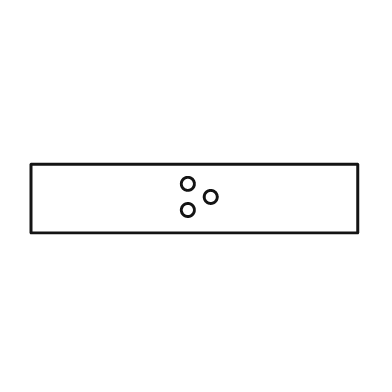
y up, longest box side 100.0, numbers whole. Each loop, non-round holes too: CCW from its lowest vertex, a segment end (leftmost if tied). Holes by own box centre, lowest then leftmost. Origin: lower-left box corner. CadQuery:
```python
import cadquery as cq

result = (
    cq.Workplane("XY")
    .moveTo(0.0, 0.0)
    .lineTo(100.0, 0.0)
    .lineTo(100.0, 21.0)
    .lineTo(0.0, 21.0)
    .close()
    .moveTo(48.0, 7.0)
    .circle(2.0)
    .moveTo(55.0, 11.0)
    .circle(2.0)
    .moveTo(48.0, 15.0)
    .circle(2.0)
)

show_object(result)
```